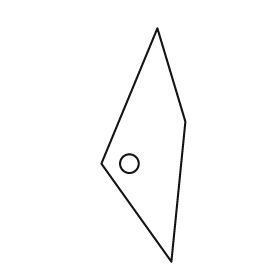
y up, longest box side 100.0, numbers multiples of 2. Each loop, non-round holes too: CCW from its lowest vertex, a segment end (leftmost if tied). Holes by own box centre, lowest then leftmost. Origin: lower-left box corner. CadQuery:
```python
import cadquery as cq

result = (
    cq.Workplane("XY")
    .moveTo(30.0, 0.0)
    .lineTo(36.0, 60.0)
    .lineTo(24.0, 100.0)
    .lineTo(0.0, 42.0)
    .close()
    .moveTo(12.0, 42.0)
    .circle(4.0)
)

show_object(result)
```